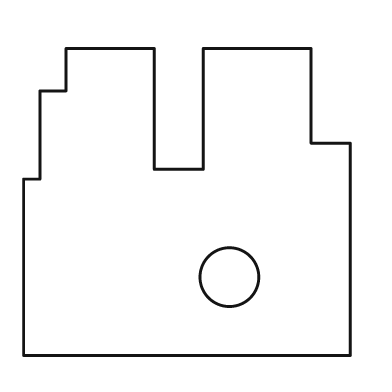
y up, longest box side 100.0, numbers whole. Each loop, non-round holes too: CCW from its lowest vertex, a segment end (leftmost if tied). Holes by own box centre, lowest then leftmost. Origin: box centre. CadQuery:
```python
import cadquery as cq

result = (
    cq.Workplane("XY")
    .moveTo(-50.0, -47.0)
    .lineTo(50.0, -47.0)
    .lineTo(50.0, 18.0)
    .lineTo(38.0, 18.0)
    .lineTo(38.0, 47.0)
    .lineTo(5.0, 47.0)
    .lineTo(5.0, 10.0)
    .lineTo(-10.0, 10.0)
    .lineTo(-10.0, 47.0)
    .lineTo(-37.0, 47.0)
    .lineTo(-37.0, 34.0)
    .lineTo(-45.0, 34.0)
    .lineTo(-45.0, 7.0)
    .lineTo(-50.0, 7.0)
    .close()
    .moveTo(13.0, -23.0)
    .circle(9.0)
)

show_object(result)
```